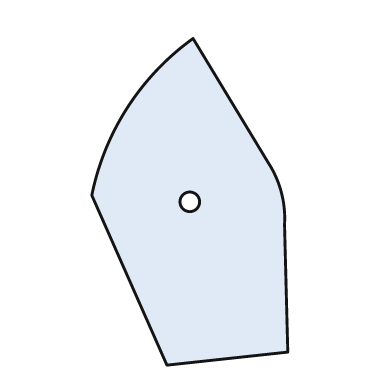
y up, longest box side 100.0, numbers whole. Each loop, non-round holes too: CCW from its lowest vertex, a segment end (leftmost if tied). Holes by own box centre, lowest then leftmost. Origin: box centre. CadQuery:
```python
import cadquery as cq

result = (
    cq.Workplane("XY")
    .moveTo(-7.0, -50.0)
    .lineTo(30.0, -46.0)
    .lineTo(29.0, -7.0)
    .threePointArc((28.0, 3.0), (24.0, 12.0))
    .lineTo(1.0, 50.0)
    .threePointArc((-19.0, 29.0), (-30.0, 2.0))
    .close()
    .moveTo(0.0, 0.0)
    .circle(3.0)
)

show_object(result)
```